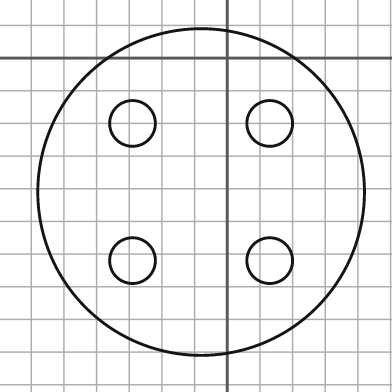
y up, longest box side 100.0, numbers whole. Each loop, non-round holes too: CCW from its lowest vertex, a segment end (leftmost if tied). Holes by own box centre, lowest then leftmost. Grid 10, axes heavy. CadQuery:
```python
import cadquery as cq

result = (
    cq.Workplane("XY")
    .moveTo(-8.0, -41.0)
    .circle(50.0)
    .moveTo(-29.0, -62.0)
    .circle(7.0)
    .moveTo(13.0, -62.0)
    .circle(7.0)
    .moveTo(-29.0, -20.0)
    .circle(7.0)
    .moveTo(13.0, -20.0)
    .circle(7.0)
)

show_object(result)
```